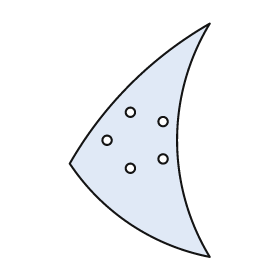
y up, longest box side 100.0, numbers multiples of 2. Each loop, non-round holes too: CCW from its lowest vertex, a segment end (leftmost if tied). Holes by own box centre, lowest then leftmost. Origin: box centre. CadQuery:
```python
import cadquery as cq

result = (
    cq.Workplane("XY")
    .moveTo(30.0, -50.0)
    .threePointArc((16.0, 0.0), (30.0, 50.0))
    .threePointArc((-4.0, 24.0), (-30.0, -10.0))
    .threePointArc((-4.0, -36.0), (30.0, -50.0))
    .close()
    .moveTo(-4.0, -12.0)
    .circle(2.0)
    .moveTo(10.0, -8.0)
    .circle(2.0)
    .moveTo(-14.0, 0.0)
    .circle(2.0)
    .moveTo(10.0, 8.0)
    .circle(2.0)
    .moveTo(-4.0, 12.0)
    .circle(2.0)
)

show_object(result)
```